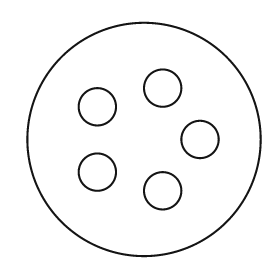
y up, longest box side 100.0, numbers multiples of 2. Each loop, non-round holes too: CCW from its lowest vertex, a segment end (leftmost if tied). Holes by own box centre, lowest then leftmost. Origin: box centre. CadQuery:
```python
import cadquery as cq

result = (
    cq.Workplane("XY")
    .moveTo(0.0, 0.0)
    .circle(50.0)
    .moveTo(8.0, -22.0)
    .circle(8.0)
    .moveTo(-20.0, -14.0)
    .circle(8.0)
    .moveTo(24.0, 0.0)
    .circle(8.0)
    .moveTo(-20.0, 14.0)
    .circle(8.0)
    .moveTo(8.0, 22.0)
    .circle(8.0)
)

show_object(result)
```